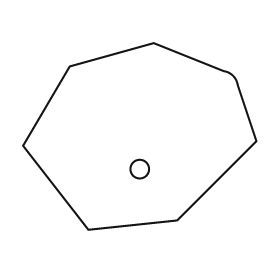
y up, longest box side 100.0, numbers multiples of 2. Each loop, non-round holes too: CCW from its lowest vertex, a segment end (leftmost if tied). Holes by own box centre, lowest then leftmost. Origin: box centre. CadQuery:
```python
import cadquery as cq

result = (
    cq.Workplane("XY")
    .moveTo(-22.0, -40.0)
    .lineTo(16.0, -36.0)
    .lineTo(50.0, -2.0)
    .lineTo(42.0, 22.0)
    .threePointArc((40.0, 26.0), (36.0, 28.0))
    .lineTo(6.0, 40.0)
    .lineTo(-30.0, 30.0)
    .lineTo(-50.0, -4.0)
    .close()
    .moveTo(0.0, -14.0)
    .circle(4.0)
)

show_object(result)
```